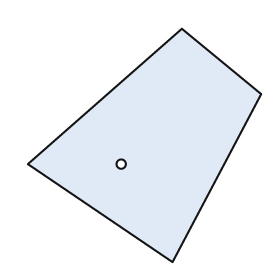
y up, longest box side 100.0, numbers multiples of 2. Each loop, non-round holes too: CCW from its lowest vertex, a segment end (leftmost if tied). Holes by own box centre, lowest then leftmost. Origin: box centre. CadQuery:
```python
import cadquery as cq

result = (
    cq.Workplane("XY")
    .moveTo(12.0, -50.0)
    .lineTo(50.0, 22.0)
    .lineTo(16.0, 50.0)
    .lineTo(-50.0, -8.0)
    .close()
    .moveTo(-10.0, -8.0)
    .circle(2.0)
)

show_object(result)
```